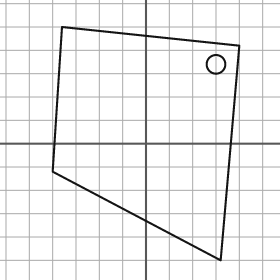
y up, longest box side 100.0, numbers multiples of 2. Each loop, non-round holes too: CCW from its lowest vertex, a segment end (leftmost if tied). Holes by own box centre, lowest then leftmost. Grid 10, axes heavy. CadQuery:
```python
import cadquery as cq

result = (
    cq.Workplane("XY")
    .moveTo(32.0, -50.0)
    .lineTo(40.0, 42.0)
    .lineTo(-36.0, 50.0)
    .lineTo(-40.0, -12.0)
    .close()
    .moveTo(30.0, 34.0)
    .circle(4.0)
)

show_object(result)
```